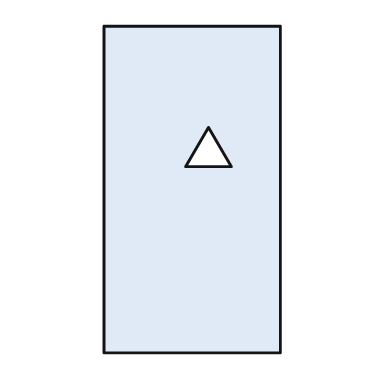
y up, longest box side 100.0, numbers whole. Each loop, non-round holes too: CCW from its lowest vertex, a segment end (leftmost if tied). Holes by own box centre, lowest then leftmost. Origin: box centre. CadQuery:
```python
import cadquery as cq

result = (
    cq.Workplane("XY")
    .moveTo(-27.0, -50.0)
    .lineTo(27.0, -50.0)
    .lineTo(27.0, 50.0)
    .lineTo(-27.0, 50.0)
    .close()
    .moveTo(-2.0, 7.0)
    .lineTo(12.0, 7.0)
    .lineTo(5.0, 19.0)
    .close()
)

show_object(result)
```